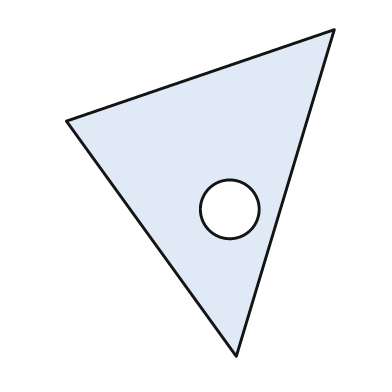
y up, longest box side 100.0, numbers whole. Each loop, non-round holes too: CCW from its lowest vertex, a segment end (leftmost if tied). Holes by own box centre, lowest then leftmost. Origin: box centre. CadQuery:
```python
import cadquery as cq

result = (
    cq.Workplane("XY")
    .moveTo(11.0, -50.0)
    .lineTo(41.0, 50.0)
    .lineTo(-41.0, 22.0)
    .close()
    .moveTo(9.0, -5.0)
    .circle(9.0)
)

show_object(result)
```